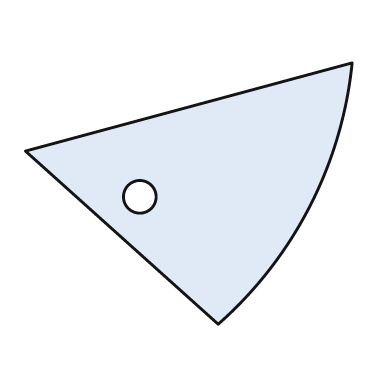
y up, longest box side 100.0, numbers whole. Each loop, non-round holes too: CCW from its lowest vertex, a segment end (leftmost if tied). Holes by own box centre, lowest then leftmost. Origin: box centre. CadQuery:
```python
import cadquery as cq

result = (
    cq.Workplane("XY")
    .moveTo(9.0, -40.0)
    .threePointArc((37.0, -4.0), (50.0, 40.0))
    .lineTo(-50.0, 13.0)
    .close()
    .moveTo(-15.0, -1.0)
    .circle(5.0)
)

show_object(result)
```